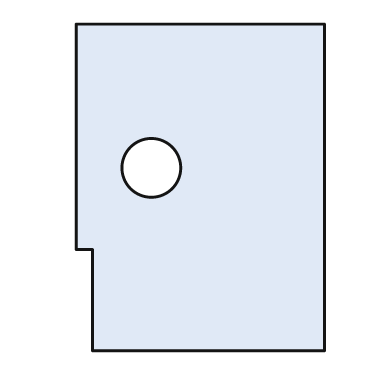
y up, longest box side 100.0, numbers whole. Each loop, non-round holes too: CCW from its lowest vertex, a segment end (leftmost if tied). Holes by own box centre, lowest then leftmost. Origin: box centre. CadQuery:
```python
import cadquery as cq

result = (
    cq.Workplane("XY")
    .moveTo(-33.0, -50.0)
    .lineTo(38.0, -50.0)
    .lineTo(38.0, 50.0)
    .lineTo(-38.0, 50.0)
    .lineTo(-38.0, -19.0)
    .lineTo(-33.0, -19.0)
    .close()
    .moveTo(-15.0, 6.0)
    .circle(9.0)
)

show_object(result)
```